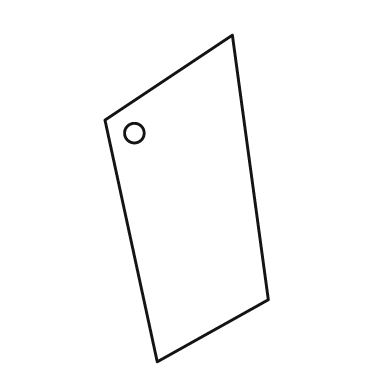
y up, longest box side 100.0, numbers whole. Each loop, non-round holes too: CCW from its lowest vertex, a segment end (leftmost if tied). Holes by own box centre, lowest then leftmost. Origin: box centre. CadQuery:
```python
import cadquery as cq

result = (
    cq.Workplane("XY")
    .moveTo(-9.0, -50.0)
    .lineTo(25.0, -31.0)
    .lineTo(14.0, 50.0)
    .lineTo(-25.0, 24.0)
    .close()
    .moveTo(-16.0, 20.0)
    .circle(3.0)
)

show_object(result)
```